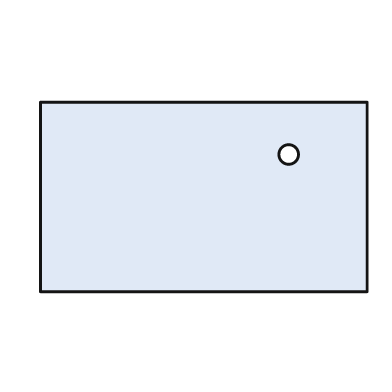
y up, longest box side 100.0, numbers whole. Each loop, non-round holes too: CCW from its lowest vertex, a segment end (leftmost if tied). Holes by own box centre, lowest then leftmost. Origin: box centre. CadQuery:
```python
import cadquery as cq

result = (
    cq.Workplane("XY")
    .moveTo(-50.0, -29.0)
    .lineTo(50.0, -29.0)
    .lineTo(50.0, 29.0)
    .lineTo(-50.0, 29.0)
    .close()
    .moveTo(26.0, 13.0)
    .circle(3.0)
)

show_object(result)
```